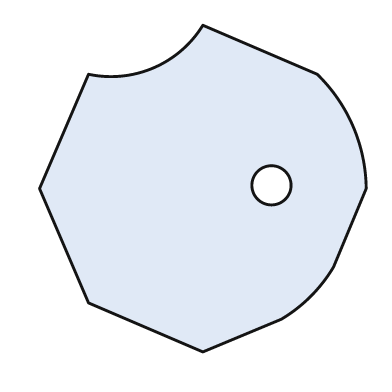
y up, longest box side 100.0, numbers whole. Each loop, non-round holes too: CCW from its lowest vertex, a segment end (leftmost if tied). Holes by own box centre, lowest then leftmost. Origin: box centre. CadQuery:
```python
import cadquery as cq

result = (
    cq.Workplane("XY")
    .moveTo(0.0, -50.0)
    .lineTo(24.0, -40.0)
    .threePointArc((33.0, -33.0), (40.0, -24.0))
    .lineTo(50.0, 0.0)
    .threePointArc((46.0, 19.0), (35.0, 35.0))
    .lineTo(0.0, 50.0)
    .threePointArc((-15.0, 37.0), (-35.0, 35.0))
    .lineTo(-50.0, 0.0)
    .lineTo(-35.0, -35.0)
    .close()
    .moveTo(21.0, 1.0)
    .circle(6.0)
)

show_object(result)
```